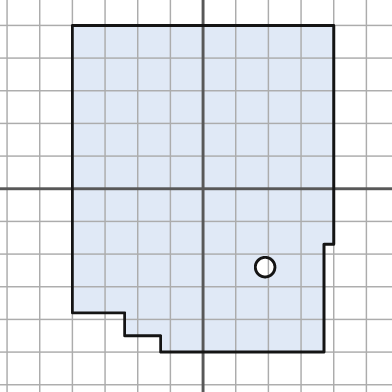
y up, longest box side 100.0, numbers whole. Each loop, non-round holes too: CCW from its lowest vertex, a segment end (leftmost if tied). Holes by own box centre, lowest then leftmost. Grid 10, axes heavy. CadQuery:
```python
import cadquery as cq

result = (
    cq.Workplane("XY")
    .moveTo(-13.0, -50.0)
    .lineTo(37.0, -50.0)
    .lineTo(37.0, -17.0)
    .lineTo(40.0, -17.0)
    .lineTo(40.0, 50.0)
    .lineTo(-40.0, 50.0)
    .lineTo(-40.0, -38.0)
    .lineTo(-24.0, -38.0)
    .lineTo(-24.0, -45.0)
    .lineTo(-13.0, -45.0)
    .close()
    .moveTo(19.0, -24.0)
    .circle(3.0)
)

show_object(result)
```